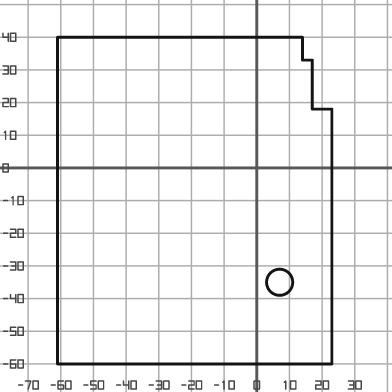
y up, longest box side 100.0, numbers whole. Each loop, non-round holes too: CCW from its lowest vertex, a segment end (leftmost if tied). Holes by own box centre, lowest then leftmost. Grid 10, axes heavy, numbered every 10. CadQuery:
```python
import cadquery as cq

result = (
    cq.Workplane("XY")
    .moveTo(-61.0, -60.0)
    .lineTo(23.0, -60.0)
    .lineTo(23.0, 18.0)
    .lineTo(17.0, 18.0)
    .lineTo(17.0, 33.0)
    .lineTo(14.0, 33.0)
    .lineTo(14.0, 40.0)
    .lineTo(-61.0, 40.0)
    .close()
    .moveTo(7.0, -35.0)
    .circle(4.0)
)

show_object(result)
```